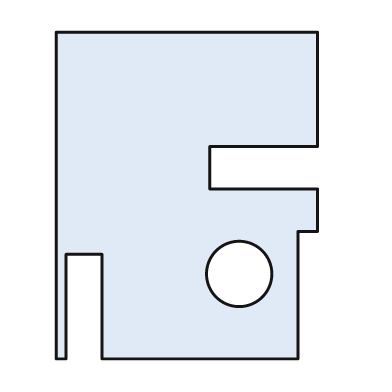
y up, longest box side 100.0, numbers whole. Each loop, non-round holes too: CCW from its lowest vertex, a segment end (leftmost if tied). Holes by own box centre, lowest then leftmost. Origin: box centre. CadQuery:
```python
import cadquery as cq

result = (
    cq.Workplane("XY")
    .moveTo(-40.0, -50.0)
    .lineTo(-37.0, -50.0)
    .lineTo(-37.0, -18.0)
    .lineTo(-26.0, -18.0)
    .lineTo(-26.0, -50.0)
    .lineTo(34.0, -50.0)
    .lineTo(34.0, -11.0)
    .lineTo(40.0, -11.0)
    .lineTo(40.0, 2.0)
    .lineTo(7.0, 2.0)
    .lineTo(7.0, 15.0)
    .lineTo(40.0, 15.0)
    .lineTo(40.0, 50.0)
    .lineTo(-40.0, 50.0)
    .close()
    .moveTo(16.0, -24.0)
    .circle(10.0)
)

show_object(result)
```